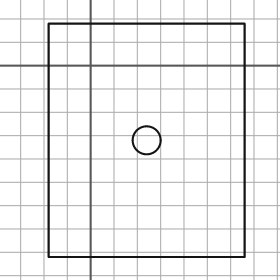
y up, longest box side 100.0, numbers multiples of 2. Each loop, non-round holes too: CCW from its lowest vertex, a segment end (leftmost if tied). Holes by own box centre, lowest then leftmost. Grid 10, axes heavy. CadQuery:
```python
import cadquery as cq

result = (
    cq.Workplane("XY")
    .moveTo(-18.0, -82.0)
    .lineTo(66.0, -82.0)
    .lineTo(66.0, 18.0)
    .lineTo(-18.0, 18.0)
    .close()
    .moveTo(24.0, -32.0)
    .circle(6.0)
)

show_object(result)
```